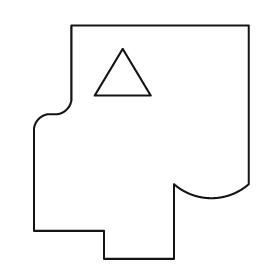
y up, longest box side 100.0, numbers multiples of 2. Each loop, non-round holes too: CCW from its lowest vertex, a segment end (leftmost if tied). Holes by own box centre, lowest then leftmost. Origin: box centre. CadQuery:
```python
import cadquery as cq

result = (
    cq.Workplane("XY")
    .moveTo(-16.0, -50.0)
    .lineTo(14.0, -50.0)
    .lineTo(14.0, -18.0)
    .threePointArc((30.0, -24.0), (46.0, -18.0))
    .lineTo(46.0, 50.0)
    .lineTo(-30.0, 50.0)
    .lineTo(-30.0, 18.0)
    .threePointArc((-32.0, 14.0), (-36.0, 12.0))
    .lineTo(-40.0, 12.0)
    .threePointArc((-44.0, 10.0), (-46.0, 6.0))
    .lineTo(-46.0, -38.0)
    .lineTo(-16.0, -38.0)
    .close()
    .moveTo(-20.0, 20.0)
    .lineTo(4.0, 20.0)
    .lineTo(-8.0, 40.0)
    .close()
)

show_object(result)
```